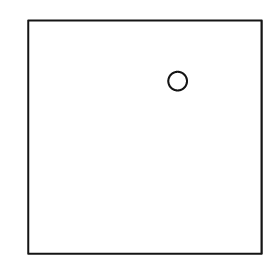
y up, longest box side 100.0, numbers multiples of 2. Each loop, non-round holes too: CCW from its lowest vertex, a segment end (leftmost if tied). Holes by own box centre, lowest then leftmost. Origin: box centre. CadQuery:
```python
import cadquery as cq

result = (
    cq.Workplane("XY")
    .moveTo(-50.0, -50.0)
    .lineTo(50.0, -50.0)
    .lineTo(50.0, 50.0)
    .lineTo(-50.0, 50.0)
    .close()
    .moveTo(14.0, 24.0)
    .circle(4.0)
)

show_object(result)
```